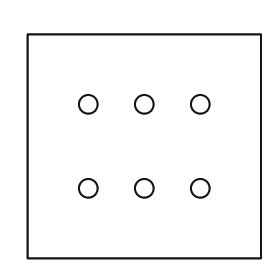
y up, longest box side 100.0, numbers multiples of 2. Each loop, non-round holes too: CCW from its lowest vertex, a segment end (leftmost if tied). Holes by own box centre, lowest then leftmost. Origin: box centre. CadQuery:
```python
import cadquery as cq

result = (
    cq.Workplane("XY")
    .moveTo(-50.0, -48.0)
    .lineTo(50.0, -48.0)
    .lineTo(50.0, 48.0)
    .lineTo(-50.0, 48.0)
    .close()
    .moveTo(-24.0, -18.0)
    .circle(4.0)
    .moveTo(0.0, -18.0)
    .circle(4.0)
    .moveTo(24.0, -18.0)
    .circle(4.0)
    .moveTo(-24.0, 18.0)
    .circle(4.0)
    .moveTo(0.0, 18.0)
    .circle(4.0)
    .moveTo(24.0, 18.0)
    .circle(4.0)
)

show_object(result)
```